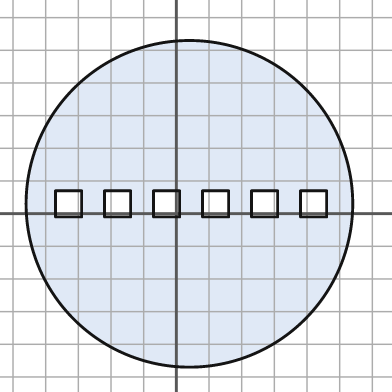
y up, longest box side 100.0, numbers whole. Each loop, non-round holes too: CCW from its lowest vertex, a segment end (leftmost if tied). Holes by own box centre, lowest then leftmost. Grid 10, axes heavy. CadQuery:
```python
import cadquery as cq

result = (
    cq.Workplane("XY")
    .moveTo(4.0, 3.0)
    .circle(50.0)
    .moveTo(-37.0, -1.0)
    .lineTo(-29.0, -1.0)
    .lineTo(-29.0, 7.0)
    .lineTo(-37.0, 7.0)
    .close()
    .moveTo(-22.0, -1.0)
    .lineTo(-14.0, -1.0)
    .lineTo(-14.0, 7.0)
    .lineTo(-22.0, 7.0)
    .close()
    .moveTo(-7.0, -1.0)
    .lineTo(1.0, -1.0)
    .lineTo(1.0, 7.0)
    .lineTo(-7.0, 7.0)
    .close()
    .moveTo(8.0, -1.0)
    .lineTo(16.0, -1.0)
    .lineTo(16.0, 7.0)
    .lineTo(8.0, 7.0)
    .close()
    .moveTo(23.0, -1.0)
    .lineTo(31.0, -1.0)
    .lineTo(31.0, 7.0)
    .lineTo(23.0, 7.0)
    .close()
    .moveTo(38.0, -1.0)
    .lineTo(46.0, -1.0)
    .lineTo(46.0, 7.0)
    .lineTo(38.0, 7.0)
    .close()
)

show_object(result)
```